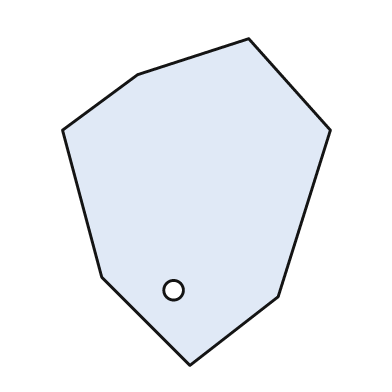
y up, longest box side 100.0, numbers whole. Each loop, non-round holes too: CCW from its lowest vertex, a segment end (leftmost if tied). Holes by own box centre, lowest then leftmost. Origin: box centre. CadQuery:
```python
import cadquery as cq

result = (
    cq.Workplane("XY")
    .moveTo(-2.0, -50.0)
    .lineTo(25.0, -29.0)
    .lineTo(41.0, 22.0)
    .lineTo(16.0, 50.0)
    .lineTo(-18.0, 39.0)
    .lineTo(-41.0, 22.0)
    .lineTo(-29.0, -23.0)
    .close()
    .moveTo(-7.0, -27.0)
    .circle(3.0)
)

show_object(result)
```